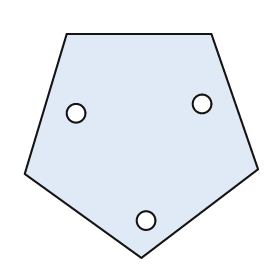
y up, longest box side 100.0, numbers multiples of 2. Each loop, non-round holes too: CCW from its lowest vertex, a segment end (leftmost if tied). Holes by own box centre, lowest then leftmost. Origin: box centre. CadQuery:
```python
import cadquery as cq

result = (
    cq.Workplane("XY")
    .moveTo(0.0, -48.0)
    .lineTo(50.0, -10.0)
    .lineTo(30.0, 48.0)
    .lineTo(-32.0, 48.0)
    .lineTo(-50.0, -12.0)
    .close()
    .moveTo(2.0, -32.0)
    .circle(4.0)
    .moveTo(-28.0, 14.0)
    .circle(4.0)
    .moveTo(26.0, 18.0)
    .circle(4.0)
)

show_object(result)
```